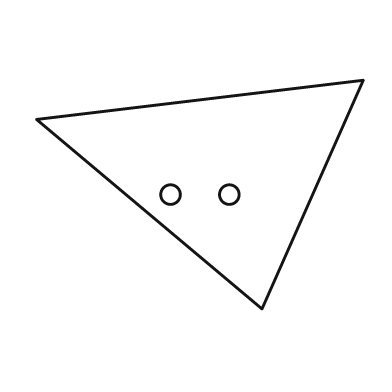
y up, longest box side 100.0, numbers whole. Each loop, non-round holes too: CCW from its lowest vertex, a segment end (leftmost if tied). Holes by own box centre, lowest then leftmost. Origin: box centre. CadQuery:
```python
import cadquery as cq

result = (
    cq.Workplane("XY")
    .moveTo(19.0, -35.0)
    .lineTo(50.0, 35.0)
    .lineTo(-50.0, 23.0)
    .close()
    .moveTo(-9.0, 0.0)
    .circle(3.0)
    .moveTo(9.0, 0.0)
    .circle(3.0)
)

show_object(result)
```